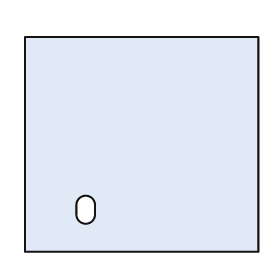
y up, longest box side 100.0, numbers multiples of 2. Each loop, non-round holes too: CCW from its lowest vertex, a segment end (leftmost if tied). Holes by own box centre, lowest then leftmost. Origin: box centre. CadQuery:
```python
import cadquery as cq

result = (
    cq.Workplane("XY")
    .moveTo(-50.0, -46.0)
    .lineTo(50.0, -46.0)
    .lineTo(50.0, 46.0)
    .lineTo(-50.0, 46.0)
    .close()
    .moveTo(-28.0, -30.0)
    .threePointArc((-24.0, -34.0), (-20.0, -30.0))
    .lineTo(-20.0, -26.0)
    .threePointArc((-24.0, -22.0), (-28.0, -26.0))
    .close()
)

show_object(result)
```